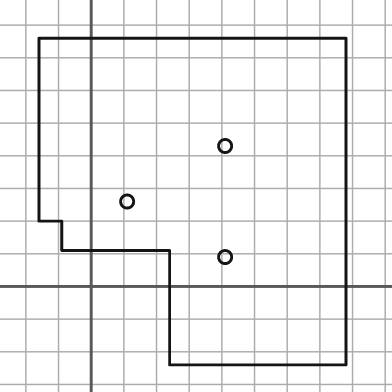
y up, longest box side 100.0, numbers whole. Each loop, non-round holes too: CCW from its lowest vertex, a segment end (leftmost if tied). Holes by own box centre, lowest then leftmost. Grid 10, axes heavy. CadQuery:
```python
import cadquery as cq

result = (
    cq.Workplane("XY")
    .moveTo(24.0, -24.0)
    .lineTo(78.0, -24.0)
    .lineTo(78.0, 76.0)
    .lineTo(-16.0, 76.0)
    .lineTo(-16.0, 20.0)
    .lineTo(-9.0, 20.0)
    .lineTo(-9.0, 11.0)
    .lineTo(24.0, 11.0)
    .close()
    .moveTo(41.0, 9.0)
    .circle(2.0)
    .moveTo(11.0, 26.0)
    .circle(2.0)
    .moveTo(41.0, 43.0)
    .circle(2.0)
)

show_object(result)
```